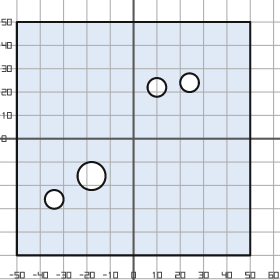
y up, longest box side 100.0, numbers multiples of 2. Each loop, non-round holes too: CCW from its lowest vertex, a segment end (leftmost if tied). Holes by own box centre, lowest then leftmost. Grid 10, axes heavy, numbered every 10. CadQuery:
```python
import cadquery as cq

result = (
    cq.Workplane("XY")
    .moveTo(-50.0, -50.0)
    .lineTo(50.0, -50.0)
    .lineTo(50.0, 50.0)
    .lineTo(-50.0, 50.0)
    .close()
    .moveTo(-34.0, -26.0)
    .circle(4.0)
    .moveTo(-18.0, -16.0)
    .circle(6.0)
    .moveTo(10.0, 22.0)
    .circle(4.0)
    .moveTo(24.0, 24.0)
    .circle(4.0)
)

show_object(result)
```